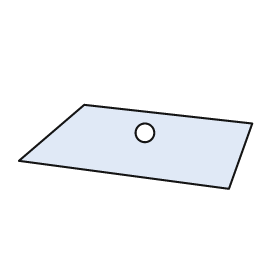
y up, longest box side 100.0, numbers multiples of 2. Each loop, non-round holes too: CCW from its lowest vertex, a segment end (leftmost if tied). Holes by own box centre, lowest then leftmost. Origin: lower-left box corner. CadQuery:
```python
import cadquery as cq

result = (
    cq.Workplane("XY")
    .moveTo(90.0, 0.0)
    .lineTo(100.0, 28.0)
    .lineTo(28.0, 36.0)
    .lineTo(0.0, 12.0)
    .close()
    .moveTo(54.0, 24.0)
    .circle(4.0)
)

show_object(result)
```